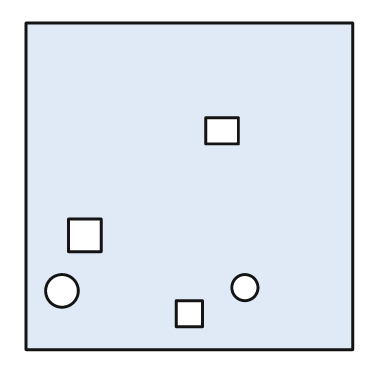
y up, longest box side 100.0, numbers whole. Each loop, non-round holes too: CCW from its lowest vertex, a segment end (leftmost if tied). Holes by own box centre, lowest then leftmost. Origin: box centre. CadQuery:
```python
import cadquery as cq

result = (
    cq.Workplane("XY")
    .moveTo(-50.0, -50.0)
    .lineTo(50.0, -50.0)
    .lineTo(50.0, 50.0)
    .lineTo(-50.0, 50.0)
    .close()
    .moveTo(-4.0, -43.0)
    .lineTo(4.0, -43.0)
    .lineTo(4.0, -35.0)
    .lineTo(-4.0, -35.0)
    .close()
    .moveTo(-39.0, -32.0)
    .circle(5.0)
    .moveTo(17.0, -31.0)
    .circle(4.0)
    .moveTo(-37.0, -20.0)
    .lineTo(-27.0, -20.0)
    .lineTo(-27.0, -10.0)
    .lineTo(-37.0, -10.0)
    .close()
    .moveTo(5.0, 13.0)
    .lineTo(15.0, 13.0)
    .lineTo(15.0, 21.0)
    .lineTo(5.0, 21.0)
    .close()
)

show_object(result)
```